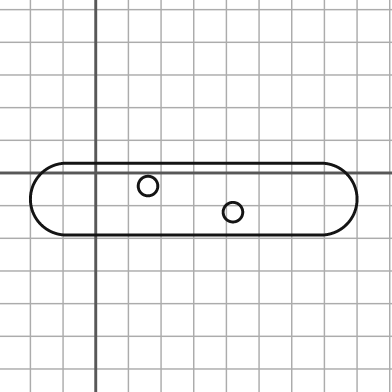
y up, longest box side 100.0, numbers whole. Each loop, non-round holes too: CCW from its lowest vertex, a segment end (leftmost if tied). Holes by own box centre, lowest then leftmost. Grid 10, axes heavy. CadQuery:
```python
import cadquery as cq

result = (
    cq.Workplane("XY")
    .moveTo(-9.0, -19.0)
    .lineTo(69.0, -19.0)
    .threePointArc((80.0, -8.0), (69.0, 3.0))
    .lineTo(-9.0, 3.0)
    .threePointArc((-20.0, -8.0), (-9.0, -19.0))
    .close()
    .moveTo(42.0, -12.0)
    .circle(3.0)
    .moveTo(16.0, -4.0)
    .circle(3.0)
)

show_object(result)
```